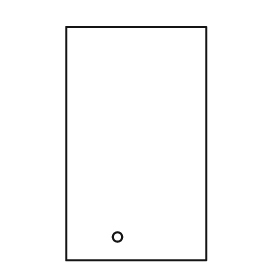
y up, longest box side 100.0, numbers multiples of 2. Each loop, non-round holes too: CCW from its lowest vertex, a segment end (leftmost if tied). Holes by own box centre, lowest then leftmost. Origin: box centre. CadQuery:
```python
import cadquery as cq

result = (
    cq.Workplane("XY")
    .moveTo(-30.0, -50.0)
    .lineTo(30.0, -50.0)
    .lineTo(30.0, 50.0)
    .lineTo(-30.0, 50.0)
    .close()
    .moveTo(-8.0, -40.0)
    .circle(2.0)
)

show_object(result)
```